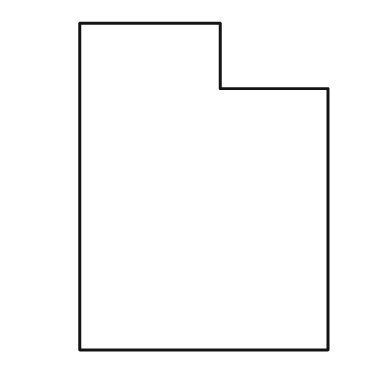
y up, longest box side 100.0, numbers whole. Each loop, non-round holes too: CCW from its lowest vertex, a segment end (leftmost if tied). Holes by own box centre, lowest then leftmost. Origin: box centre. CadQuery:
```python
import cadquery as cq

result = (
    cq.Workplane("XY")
    .moveTo(-38.0, -50.0)
    .lineTo(38.0, -50.0)
    .lineTo(38.0, 30.0)
    .lineTo(5.0, 30.0)
    .lineTo(5.0, 50.0)
    .lineTo(-38.0, 50.0)
    .close()
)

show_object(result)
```